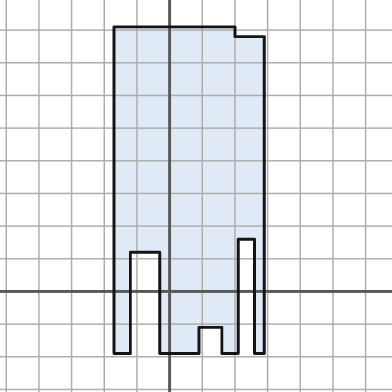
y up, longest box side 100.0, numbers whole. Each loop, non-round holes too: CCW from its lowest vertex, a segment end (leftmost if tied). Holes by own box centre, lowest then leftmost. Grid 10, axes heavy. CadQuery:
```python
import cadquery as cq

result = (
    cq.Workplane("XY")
    .moveTo(-17.0, -19.0)
    .lineTo(-12.0, -19.0)
    .lineTo(-12.0, 12.0)
    .lineTo(-3.0, 12.0)
    .lineTo(-3.0, -19.0)
    .lineTo(9.0, -19.0)
    .lineTo(9.0, -11.0)
    .lineTo(16.0, -11.0)
    .lineTo(16.0, -19.0)
    .lineTo(21.0, -19.0)
    .lineTo(21.0, 16.0)
    .lineTo(26.0, 16.0)
    .lineTo(26.0, -19.0)
    .lineTo(29.0, -19.0)
    .lineTo(29.0, 78.0)
    .lineTo(20.0, 78.0)
    .lineTo(20.0, 81.0)
    .lineTo(-17.0, 81.0)
    .close()
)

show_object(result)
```